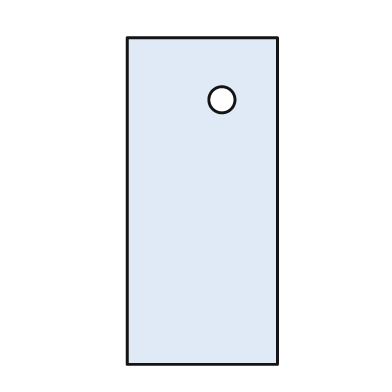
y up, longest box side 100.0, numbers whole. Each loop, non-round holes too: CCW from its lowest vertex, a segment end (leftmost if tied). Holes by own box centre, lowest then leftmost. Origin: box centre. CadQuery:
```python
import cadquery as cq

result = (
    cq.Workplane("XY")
    .moveTo(-23.0, -50.0)
    .lineTo(23.0, -50.0)
    .lineTo(23.0, 50.0)
    .lineTo(-23.0, 50.0)
    .close()
    .moveTo(6.0, 31.0)
    .circle(4.0)
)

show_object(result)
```